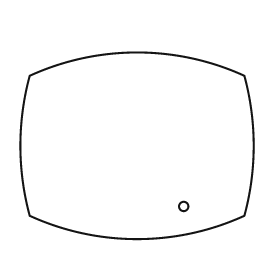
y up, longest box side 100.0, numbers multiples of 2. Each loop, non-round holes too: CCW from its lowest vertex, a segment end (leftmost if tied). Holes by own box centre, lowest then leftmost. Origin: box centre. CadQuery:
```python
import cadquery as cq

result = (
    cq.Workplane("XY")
    .moveTo(-46.0, -30.0)
    .threePointArc((0.0, -40.0), (46.0, -30.0))
    .threePointArc((50.0, 0.0), (46.0, 30.0))
    .threePointArc((0.0, 40.0), (-46.0, 30.0))
    .threePointArc((-50.0, 0.0), (-46.0, -30.0))
    .close()
    .moveTo(20.0, -26.0)
    .circle(2.0)
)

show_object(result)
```